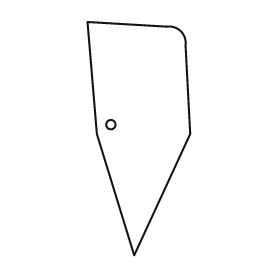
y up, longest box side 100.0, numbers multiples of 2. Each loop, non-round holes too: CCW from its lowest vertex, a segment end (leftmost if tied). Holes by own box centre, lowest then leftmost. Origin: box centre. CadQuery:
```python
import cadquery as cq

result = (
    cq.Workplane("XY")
    .moveTo(-2.0, -50.0)
    .lineTo(22.0, 2.0)
    .lineTo(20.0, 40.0)
    .threePointArc((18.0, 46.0), (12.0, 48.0))
    .lineTo(-22.0, 50.0)
    .lineTo(-18.0, 2.0)
    .close()
    .moveTo(-12.0, 6.0)
    .circle(2.0)
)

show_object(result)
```